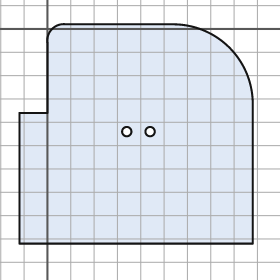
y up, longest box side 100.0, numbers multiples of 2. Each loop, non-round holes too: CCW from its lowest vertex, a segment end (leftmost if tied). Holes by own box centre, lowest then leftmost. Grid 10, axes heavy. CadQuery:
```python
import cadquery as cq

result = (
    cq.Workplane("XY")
    .moveTo(-12.0, -92.0)
    .lineTo(88.0, -92.0)
    .lineTo(88.0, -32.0)
    .threePointArc((78.0, -8.0), (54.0, 2.0))
    .lineTo(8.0, 2.0)
    .threePointArc((2.0, 0.0), (0.0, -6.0))
    .lineTo(0.0, -36.0)
    .lineTo(-12.0, -36.0)
    .close()
    .moveTo(34.0, -44.0)
    .circle(2.0)
    .moveTo(44.0, -44.0)
    .circle(2.0)
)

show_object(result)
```